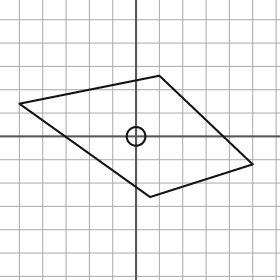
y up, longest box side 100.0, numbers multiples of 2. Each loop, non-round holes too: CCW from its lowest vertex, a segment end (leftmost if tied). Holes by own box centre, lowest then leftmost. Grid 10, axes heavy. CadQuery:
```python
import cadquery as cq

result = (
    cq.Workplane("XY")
    .moveTo(6.0, -26.0)
    .lineTo(50.0, -12.0)
    .lineTo(10.0, 26.0)
    .lineTo(-50.0, 14.0)
    .close()
    .moveTo(0.0, 0.0)
    .circle(4.0)
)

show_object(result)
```